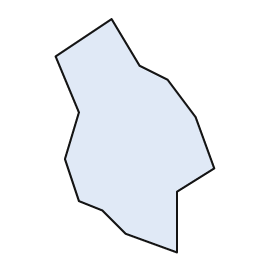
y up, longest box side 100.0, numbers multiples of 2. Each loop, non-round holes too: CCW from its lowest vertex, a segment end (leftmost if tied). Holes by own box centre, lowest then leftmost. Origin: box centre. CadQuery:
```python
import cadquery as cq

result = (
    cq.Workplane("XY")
    .moveTo(18.0, -50.0)
    .lineTo(18.0, -24.0)
    .lineTo(34.0, -14.0)
    .lineTo(26.0, 8.0)
    .lineTo(14.0, 24.0)
    .lineTo(2.0, 30.0)
    .lineTo(-10.0, 50.0)
    .lineTo(-34.0, 34.0)
    .lineTo(-24.0, 10.0)
    .lineTo(-30.0, -10.0)
    .lineTo(-24.0, -28.0)
    .lineTo(-14.0, -32.0)
    .lineTo(-4.0, -42.0)
    .close()
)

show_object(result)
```